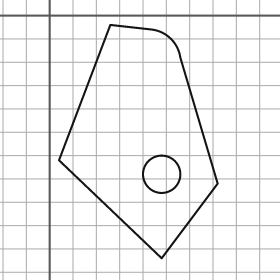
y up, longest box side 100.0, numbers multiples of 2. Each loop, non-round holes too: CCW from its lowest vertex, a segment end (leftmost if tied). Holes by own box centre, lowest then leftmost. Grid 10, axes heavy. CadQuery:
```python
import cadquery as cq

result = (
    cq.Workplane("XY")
    .moveTo(48.0, -104.0)
    .lineTo(72.0, -72.0)
    .lineTo(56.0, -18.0)
    .threePointArc((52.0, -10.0), (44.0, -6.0))
    .lineTo(26.0, -4.0)
    .lineTo(4.0, -62.0)
    .close()
    .moveTo(48.0, -68.0)
    .circle(8.0)
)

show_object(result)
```